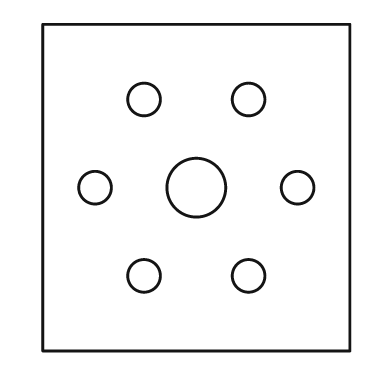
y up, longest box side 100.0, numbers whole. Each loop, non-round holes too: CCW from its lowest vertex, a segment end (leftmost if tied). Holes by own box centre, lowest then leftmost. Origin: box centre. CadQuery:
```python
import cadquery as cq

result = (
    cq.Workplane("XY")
    .moveTo(-47.0, -50.0)
    .lineTo(47.0, -50.0)
    .lineTo(47.0, 50.0)
    .lineTo(-47.0, 50.0)
    .close()
    .moveTo(-16.0, -27.0)
    .circle(5.0)
    .moveTo(16.0, -27.0)
    .circle(5.0)
    .moveTo(-31.0, 0.0)
    .circle(5.0)
    .moveTo(0.0, 0.0)
    .circle(9.0)
    .moveTo(31.0, 0.0)
    .circle(5.0)
    .moveTo(-16.0, 27.0)
    .circle(5.0)
    .moveTo(16.0, 27.0)
    .circle(5.0)
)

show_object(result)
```